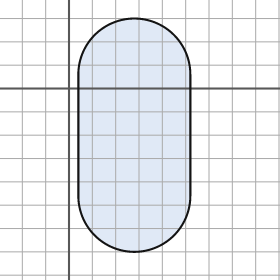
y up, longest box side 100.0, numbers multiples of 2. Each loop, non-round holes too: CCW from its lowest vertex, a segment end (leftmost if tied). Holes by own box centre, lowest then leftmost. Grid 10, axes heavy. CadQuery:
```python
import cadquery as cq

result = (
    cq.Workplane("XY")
    .moveTo(4.0, -46.0)
    .threePointArc((28.0, -70.0), (52.0, -46.0))
    .lineTo(52.0, 6.0)
    .threePointArc((28.0, 30.0), (4.0, 6.0))
    .close()
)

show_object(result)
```